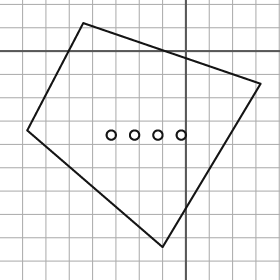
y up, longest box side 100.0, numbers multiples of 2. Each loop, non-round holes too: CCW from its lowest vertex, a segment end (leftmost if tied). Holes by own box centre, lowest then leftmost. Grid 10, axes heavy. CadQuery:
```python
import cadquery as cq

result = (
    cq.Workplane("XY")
    .moveTo(-10.0, -84.0)
    .lineTo(32.0, -14.0)
    .lineTo(-44.0, 12.0)
    .lineTo(-68.0, -34.0)
    .close()
    .moveTo(-32.0, -36.0)
    .circle(2.0)
    .moveTo(-22.0, -36.0)
    .circle(2.0)
    .moveTo(-12.0, -36.0)
    .circle(2.0)
    .moveTo(-2.0, -36.0)
    .circle(2.0)
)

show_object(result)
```